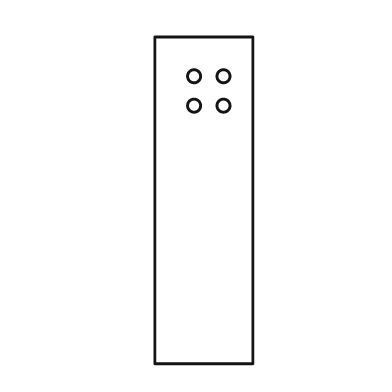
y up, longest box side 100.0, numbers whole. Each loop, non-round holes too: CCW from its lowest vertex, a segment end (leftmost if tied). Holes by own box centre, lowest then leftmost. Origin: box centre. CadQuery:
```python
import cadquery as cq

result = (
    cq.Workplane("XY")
    .moveTo(-15.0, -50.0)
    .lineTo(15.0, -50.0)
    .lineTo(15.0, 50.0)
    .lineTo(-15.0, 50.0)
    .close()
    .moveTo(-3.0, 29.0)
    .circle(2.0)
    .moveTo(6.0, 29.0)
    .circle(2.0)
    .moveTo(-3.0, 38.0)
    .circle(2.0)
    .moveTo(6.0, 38.0)
    .circle(2.0)
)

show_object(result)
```